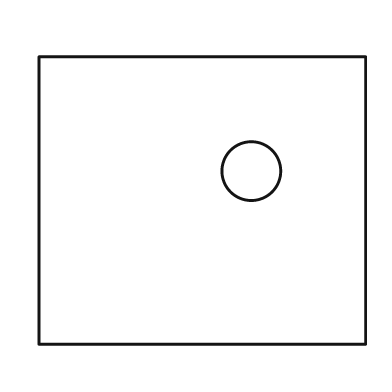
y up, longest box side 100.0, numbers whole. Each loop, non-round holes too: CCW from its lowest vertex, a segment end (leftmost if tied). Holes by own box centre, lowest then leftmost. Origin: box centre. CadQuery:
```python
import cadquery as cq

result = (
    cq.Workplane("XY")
    .moveTo(-50.0, -44.0)
    .lineTo(50.0, -44.0)
    .lineTo(50.0, 44.0)
    .lineTo(-50.0, 44.0)
    .close()
    .moveTo(15.0, 9.0)
    .circle(9.0)
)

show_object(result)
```